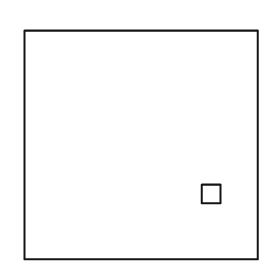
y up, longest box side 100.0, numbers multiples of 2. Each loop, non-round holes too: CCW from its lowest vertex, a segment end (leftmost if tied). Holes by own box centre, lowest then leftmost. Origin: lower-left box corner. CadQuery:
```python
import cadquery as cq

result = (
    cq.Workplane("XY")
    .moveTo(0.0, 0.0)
    .lineTo(100.0, 0.0)
    .lineTo(100.0, 98.0)
    .lineTo(0.0, 98.0)
    .close()
    .moveTo(76.0, 24.0)
    .lineTo(84.0, 24.0)
    .lineTo(84.0, 32.0)
    .lineTo(76.0, 32.0)
    .close()
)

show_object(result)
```